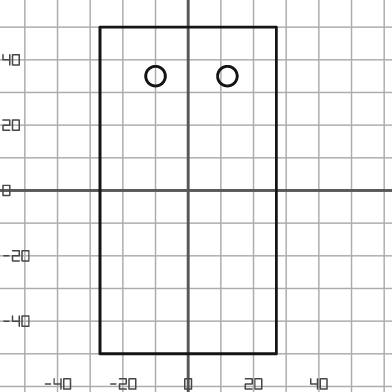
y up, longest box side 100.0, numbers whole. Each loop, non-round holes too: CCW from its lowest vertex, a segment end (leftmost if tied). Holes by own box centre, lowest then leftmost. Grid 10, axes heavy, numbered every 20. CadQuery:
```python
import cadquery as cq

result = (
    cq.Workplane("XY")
    .moveTo(-27.0, -50.0)
    .lineTo(27.0, -50.0)
    .lineTo(27.0, 50.0)
    .lineTo(-27.0, 50.0)
    .close()
    .moveTo(-10.0, 35.0)
    .circle(3.0)
    .moveTo(12.0, 35.0)
    .circle(3.0)
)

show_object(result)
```